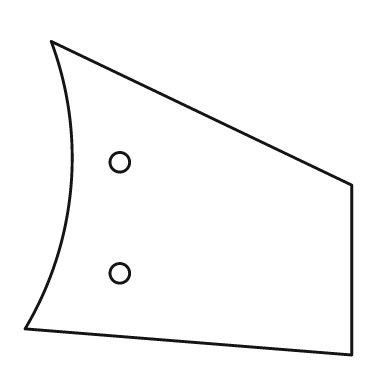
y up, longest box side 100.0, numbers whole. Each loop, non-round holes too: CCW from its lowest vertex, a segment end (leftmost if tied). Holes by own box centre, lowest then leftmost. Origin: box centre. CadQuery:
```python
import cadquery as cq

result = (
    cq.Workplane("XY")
    .moveTo(50.0, -48.0)
    .lineTo(50.0, 4.0)
    .lineTo(-42.0, 48.0)
    .threePointArc((-36.0, 3.0), (-50.0, -40.0))
    .close()
    .moveTo(-21.0, -23.0)
    .circle(3.0)
    .moveTo(-21.0, 11.0)
    .circle(3.0)
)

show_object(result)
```